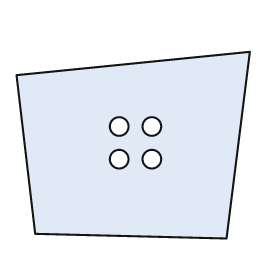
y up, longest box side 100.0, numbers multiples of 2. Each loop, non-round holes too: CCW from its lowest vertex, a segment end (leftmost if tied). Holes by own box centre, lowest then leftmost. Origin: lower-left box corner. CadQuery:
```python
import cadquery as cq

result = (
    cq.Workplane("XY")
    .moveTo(90.0, 0.0)
    .lineTo(100.0, 80.0)
    .lineTo(0.0, 70.0)
    .lineTo(8.0, 2.0)
    .close()
    .moveTo(44.0, 34.0)
    .circle(4.0)
    .moveTo(58.0, 34.0)
    .circle(4.0)
    .moveTo(44.0, 48.0)
    .circle(4.0)
    .moveTo(58.0, 48.0)
    .circle(4.0)
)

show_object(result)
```